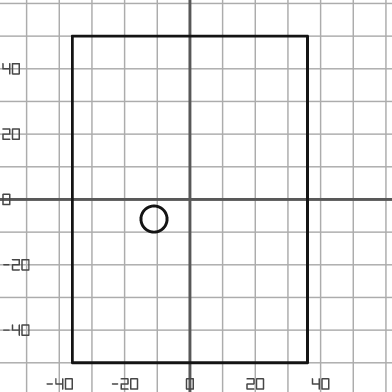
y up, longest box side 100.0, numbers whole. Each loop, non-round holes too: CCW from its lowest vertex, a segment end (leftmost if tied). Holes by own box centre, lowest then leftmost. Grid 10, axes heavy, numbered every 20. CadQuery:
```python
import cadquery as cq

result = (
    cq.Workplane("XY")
    .moveTo(-36.0, -50.0)
    .lineTo(36.0, -50.0)
    .lineTo(36.0, 50.0)
    .lineTo(-36.0, 50.0)
    .close()
    .moveTo(-11.0, -6.0)
    .circle(4.0)
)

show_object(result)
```